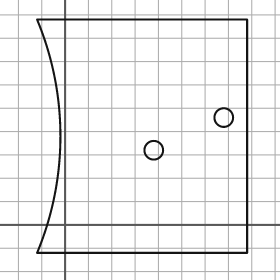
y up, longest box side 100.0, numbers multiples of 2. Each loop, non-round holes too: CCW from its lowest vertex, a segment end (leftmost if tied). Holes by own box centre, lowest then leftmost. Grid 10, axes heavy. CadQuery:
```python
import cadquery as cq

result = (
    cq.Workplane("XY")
    .moveTo(-12.0, -12.0)
    .lineTo(78.0, -12.0)
    .lineTo(78.0, 88.0)
    .lineTo(-12.0, 88.0)
    .threePointArc((-2.0, 38.0), (-12.0, -12.0))
    .close()
    .moveTo(38.0, 32.0)
    .circle(4.0)
    .moveTo(68.0, 46.0)
    .circle(4.0)
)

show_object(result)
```